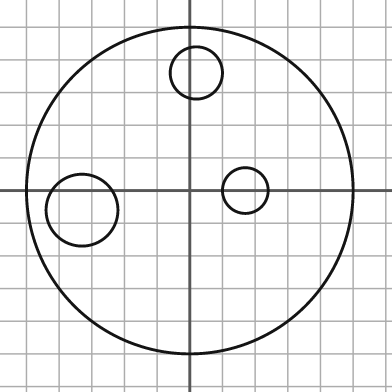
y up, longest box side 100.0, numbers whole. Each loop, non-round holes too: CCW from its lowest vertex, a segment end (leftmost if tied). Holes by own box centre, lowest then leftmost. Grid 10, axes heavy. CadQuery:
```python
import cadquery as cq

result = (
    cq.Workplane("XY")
    .moveTo(0.0, 0.0)
    .circle(50.0)
    .moveTo(-33.0, -6.0)
    .circle(11.0)
    .moveTo(17.0, 0.0)
    .circle(7.0)
    .moveTo(2.0, 36.0)
    .circle(8.0)
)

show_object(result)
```